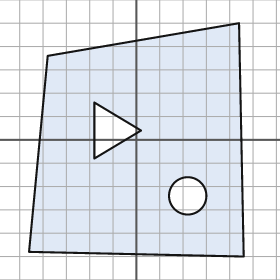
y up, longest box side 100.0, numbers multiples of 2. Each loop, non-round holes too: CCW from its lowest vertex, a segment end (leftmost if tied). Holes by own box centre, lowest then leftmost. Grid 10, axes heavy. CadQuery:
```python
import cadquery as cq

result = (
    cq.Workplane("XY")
    .moveTo(46.0, -50.0)
    .lineTo(44.0, 50.0)
    .lineTo(-38.0, 36.0)
    .lineTo(-46.0, -48.0)
    .close()
    .moveTo(22.0, -24.0)
    .circle(8.0)
    .moveTo(-18.0, -8.0)
    .lineTo(2.0, 4.0)
    .lineTo(-18.0, 16.0)
    .close()
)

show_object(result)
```